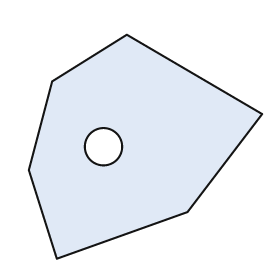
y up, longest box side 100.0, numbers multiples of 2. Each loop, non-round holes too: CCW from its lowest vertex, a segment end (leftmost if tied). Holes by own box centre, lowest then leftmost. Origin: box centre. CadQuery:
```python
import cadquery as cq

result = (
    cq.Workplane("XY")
    .moveTo(-38.0, -48.0)
    .lineTo(18.0, -28.0)
    .lineTo(50.0, 14.0)
    .lineTo(-8.0, 48.0)
    .lineTo(-40.0, 28.0)
    .lineTo(-50.0, -10.0)
    .close()
    .moveTo(-18.0, 0.0)
    .circle(8.0)
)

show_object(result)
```